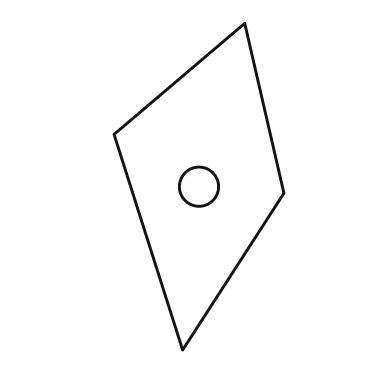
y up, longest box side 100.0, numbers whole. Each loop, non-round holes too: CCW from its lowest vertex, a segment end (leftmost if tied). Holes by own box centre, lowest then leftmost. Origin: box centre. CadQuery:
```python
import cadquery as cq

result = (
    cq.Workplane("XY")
    .moveTo(-5.0, -50.0)
    .lineTo(26.0, -2.0)
    .lineTo(14.0, 50.0)
    .lineTo(-26.0, 16.0)
    .close()
    .moveTo(0.0, 0.0)
    .circle(6.0)
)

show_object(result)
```